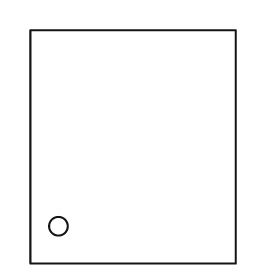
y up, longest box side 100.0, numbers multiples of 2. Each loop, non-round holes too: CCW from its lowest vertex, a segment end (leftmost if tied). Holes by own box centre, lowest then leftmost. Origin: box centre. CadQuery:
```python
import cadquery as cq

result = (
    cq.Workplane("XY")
    .moveTo(-44.0, -50.0)
    .lineTo(44.0, -50.0)
    .lineTo(44.0, 50.0)
    .lineTo(-44.0, 50.0)
    .close()
    .moveTo(-32.0, -34.0)
    .circle(4.0)
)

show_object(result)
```